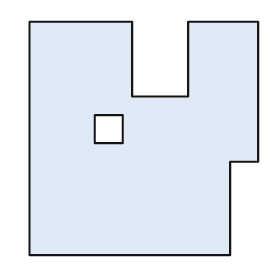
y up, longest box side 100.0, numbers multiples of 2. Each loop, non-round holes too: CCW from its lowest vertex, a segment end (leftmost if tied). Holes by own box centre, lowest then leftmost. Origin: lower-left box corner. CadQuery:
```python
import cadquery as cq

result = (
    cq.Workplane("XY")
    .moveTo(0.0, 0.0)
    .lineTo(86.0, 0.0)
    .lineTo(86.0, 40.0)
    .lineTo(98.0, 40.0)
    .lineTo(98.0, 100.0)
    .lineTo(68.0, 100.0)
    .lineTo(68.0, 68.0)
    .lineTo(44.0, 68.0)
    .lineTo(44.0, 100.0)
    .lineTo(0.0, 100.0)
    .close()
    .moveTo(28.0, 48.0)
    .lineTo(40.0, 48.0)
    .lineTo(40.0, 60.0)
    .lineTo(28.0, 60.0)
    .close()
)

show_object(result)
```